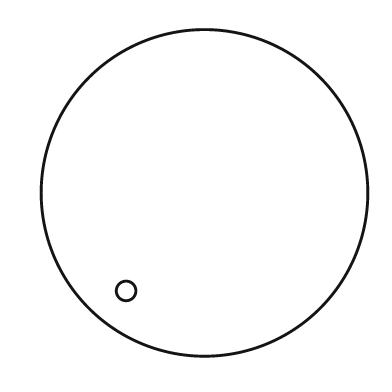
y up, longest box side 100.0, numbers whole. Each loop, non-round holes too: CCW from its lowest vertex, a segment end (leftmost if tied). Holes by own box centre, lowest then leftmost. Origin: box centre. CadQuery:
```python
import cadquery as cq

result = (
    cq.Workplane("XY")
    .moveTo(0.0, 0.0)
    .circle(50.0)
    .moveTo(-24.0, -30.0)
    .circle(3.0)
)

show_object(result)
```